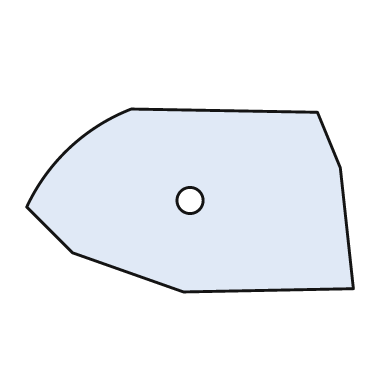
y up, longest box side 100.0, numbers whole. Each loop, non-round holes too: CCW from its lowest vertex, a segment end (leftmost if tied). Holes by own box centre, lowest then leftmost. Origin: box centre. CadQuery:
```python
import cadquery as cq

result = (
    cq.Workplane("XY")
    .moveTo(-2.0, -28.0)
    .lineTo(50.0, -27.0)
    .lineTo(46.0, 10.0)
    .lineTo(39.0, 27.0)
    .lineTo(-18.0, 28.0)
    .threePointArc((-37.0, 16.0), (-50.0, -2.0))
    .lineTo(-36.0, -16.0)
    .close()
    .moveTo(0.0, 0.0)
    .circle(4.0)
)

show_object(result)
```